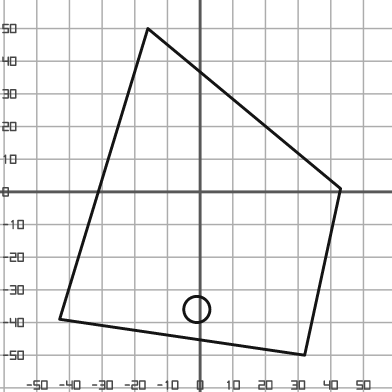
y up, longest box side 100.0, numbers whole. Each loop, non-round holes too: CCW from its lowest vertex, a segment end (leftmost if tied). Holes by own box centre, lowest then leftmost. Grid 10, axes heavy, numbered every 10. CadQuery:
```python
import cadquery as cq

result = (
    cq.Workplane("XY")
    .moveTo(32.0, -50.0)
    .lineTo(43.0, 1.0)
    .lineTo(-16.0, 50.0)
    .lineTo(-43.0, -39.0)
    .close()
    .moveTo(-1.0, -36.0)
    .circle(4.0)
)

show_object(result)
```